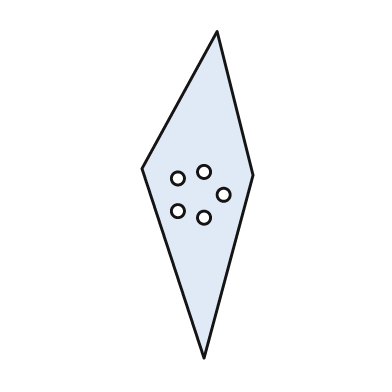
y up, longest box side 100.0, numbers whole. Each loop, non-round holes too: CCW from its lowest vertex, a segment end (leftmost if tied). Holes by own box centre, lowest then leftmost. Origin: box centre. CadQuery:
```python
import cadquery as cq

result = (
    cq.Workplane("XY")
    .moveTo(2.0, -50.0)
    .lineTo(17.0, 6.0)
    .lineTo(6.0, 50.0)
    .lineTo(-17.0, 8.0)
    .close()
    .moveTo(2.0, -7.0)
    .circle(2.0)
    .moveTo(-6.0, -5.0)
    .circle(2.0)
    .moveTo(8.0, 0.0)
    .circle(2.0)
    .moveTo(-6.0, 5.0)
    .circle(2.0)
    .moveTo(2.0, 7.0)
    .circle(2.0)
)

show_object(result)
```